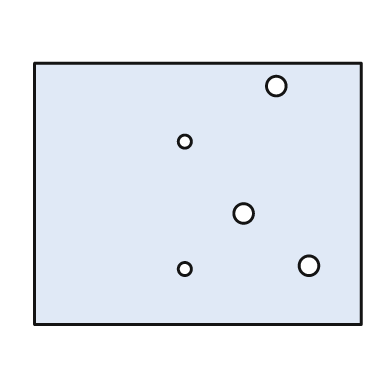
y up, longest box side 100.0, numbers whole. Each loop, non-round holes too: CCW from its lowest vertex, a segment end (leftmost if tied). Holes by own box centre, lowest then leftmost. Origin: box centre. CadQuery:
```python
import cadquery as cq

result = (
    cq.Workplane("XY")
    .moveTo(-50.0, -40.0)
    .lineTo(50.0, -40.0)
    .lineTo(50.0, 40.0)
    .lineTo(-50.0, 40.0)
    .close()
    .moveTo(-4.0, -23.0)
    .circle(2.0)
    .moveTo(34.0, -22.0)
    .circle(3.0)
    .moveTo(14.0, -6.0)
    .circle(3.0)
    .moveTo(-4.0, 16.0)
    .circle(2.0)
    .moveTo(24.0, 33.0)
    .circle(3.0)
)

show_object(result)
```